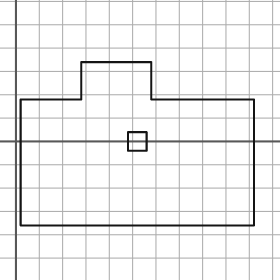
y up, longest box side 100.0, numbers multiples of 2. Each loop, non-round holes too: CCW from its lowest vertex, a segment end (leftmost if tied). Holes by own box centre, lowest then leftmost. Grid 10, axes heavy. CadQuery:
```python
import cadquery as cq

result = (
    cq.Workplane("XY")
    .moveTo(2.0, -36.0)
    .lineTo(102.0, -36.0)
    .lineTo(102.0, 18.0)
    .lineTo(58.0, 18.0)
    .lineTo(58.0, 34.0)
    .lineTo(28.0, 34.0)
    .lineTo(28.0, 18.0)
    .lineTo(2.0, 18.0)
    .close()
    .moveTo(48.0, -4.0)
    .lineTo(56.0, -4.0)
    .lineTo(56.0, 4.0)
    .lineTo(48.0, 4.0)
    .close()
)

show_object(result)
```